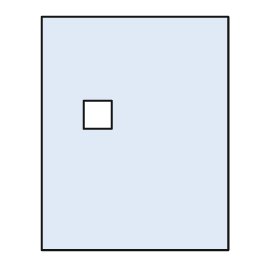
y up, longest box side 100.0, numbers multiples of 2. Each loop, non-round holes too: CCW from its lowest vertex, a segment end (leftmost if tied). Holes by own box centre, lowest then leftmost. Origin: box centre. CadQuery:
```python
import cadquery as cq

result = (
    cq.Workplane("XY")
    .moveTo(-40.0, -50.0)
    .lineTo(40.0, -50.0)
    .lineTo(40.0, 50.0)
    .lineTo(-40.0, 50.0)
    .close()
    .moveTo(-22.0, 2.0)
    .lineTo(-10.0, 2.0)
    .lineTo(-10.0, 14.0)
    .lineTo(-22.0, 14.0)
    .close()
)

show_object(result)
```